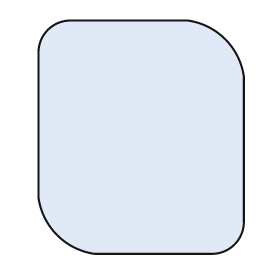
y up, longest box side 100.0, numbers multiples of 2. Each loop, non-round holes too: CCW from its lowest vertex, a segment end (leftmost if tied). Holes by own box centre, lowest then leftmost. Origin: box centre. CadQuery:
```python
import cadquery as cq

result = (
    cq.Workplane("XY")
    .moveTo(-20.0, -50.0)
    .lineTo(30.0, -50.0)
    .threePointArc((40.0, -46.0), (44.0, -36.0))
    .lineTo(44.0, 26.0)
    .threePointArc((36.0, 42.0), (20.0, 50.0))
    .lineTo(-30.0, 50.0)
    .threePointArc((-40.0, 46.0), (-44.0, 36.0))
    .lineTo(-44.0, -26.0)
    .threePointArc((-36.0, -42.0), (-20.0, -50.0))
    .close()
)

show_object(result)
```